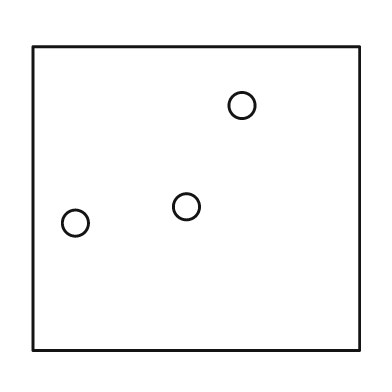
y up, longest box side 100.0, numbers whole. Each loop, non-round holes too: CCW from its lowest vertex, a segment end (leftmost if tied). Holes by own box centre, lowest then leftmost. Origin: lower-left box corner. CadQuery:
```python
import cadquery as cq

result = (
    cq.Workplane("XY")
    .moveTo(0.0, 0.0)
    .lineTo(100.0, 0.0)
    .lineTo(100.0, 93.0)
    .lineTo(0.0, 93.0)
    .close()
    .moveTo(13.0, 39.0)
    .circle(4.0)
    .moveTo(47.0, 44.0)
    .circle(4.0)
    .moveTo(64.0, 75.0)
    .circle(4.0)
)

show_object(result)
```